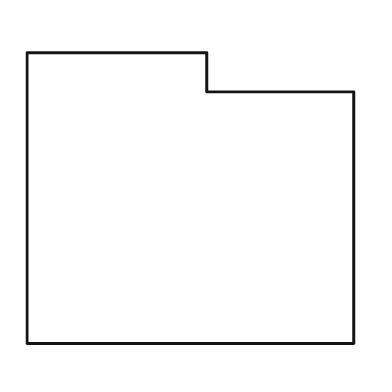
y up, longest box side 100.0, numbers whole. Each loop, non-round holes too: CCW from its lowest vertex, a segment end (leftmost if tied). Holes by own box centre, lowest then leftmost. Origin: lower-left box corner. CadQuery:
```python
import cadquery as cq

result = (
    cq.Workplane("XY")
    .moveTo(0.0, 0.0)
    .lineTo(100.0, 0.0)
    .lineTo(100.0, 77.0)
    .lineTo(55.0, 77.0)
    .lineTo(55.0, 89.0)
    .lineTo(0.0, 89.0)
    .close()
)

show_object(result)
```